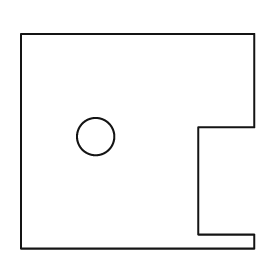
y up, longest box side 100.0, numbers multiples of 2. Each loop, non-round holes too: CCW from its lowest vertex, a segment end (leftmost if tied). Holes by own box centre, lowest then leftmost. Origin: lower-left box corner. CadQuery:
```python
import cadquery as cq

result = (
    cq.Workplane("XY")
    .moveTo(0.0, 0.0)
    .lineTo(100.0, 0.0)
    .lineTo(100.0, 6.0)
    .lineTo(76.0, 6.0)
    .lineTo(76.0, 52.0)
    .lineTo(100.0, 52.0)
    .lineTo(100.0, 92.0)
    .lineTo(0.0, 92.0)
    .close()
    .moveTo(32.0, 48.0)
    .circle(8.0)
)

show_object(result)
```